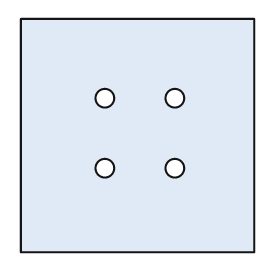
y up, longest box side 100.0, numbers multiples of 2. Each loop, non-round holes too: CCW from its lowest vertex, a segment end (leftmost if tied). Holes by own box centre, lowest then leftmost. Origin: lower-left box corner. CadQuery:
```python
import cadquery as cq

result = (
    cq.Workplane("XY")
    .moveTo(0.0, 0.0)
    .lineTo(100.0, 0.0)
    .lineTo(100.0, 100.0)
    .lineTo(0.0, 100.0)
    .close()
    .moveTo(36.0, 36.0)
    .circle(4.0)
    .moveTo(66.0, 36.0)
    .circle(4.0)
    .moveTo(36.0, 66.0)
    .circle(4.0)
    .moveTo(66.0, 66.0)
    .circle(4.0)
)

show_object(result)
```